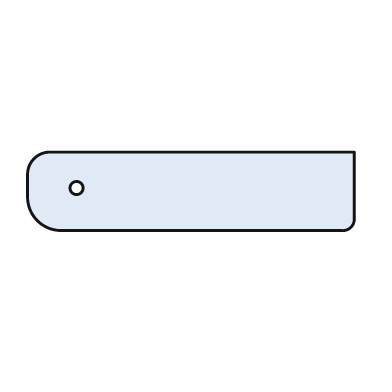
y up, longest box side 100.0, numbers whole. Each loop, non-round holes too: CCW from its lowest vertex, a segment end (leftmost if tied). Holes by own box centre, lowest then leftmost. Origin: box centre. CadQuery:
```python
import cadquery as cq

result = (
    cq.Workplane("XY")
    .moveTo(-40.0, -12.0)
    .lineTo(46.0, -12.0)
    .threePointArc((49.0, -11.0), (50.0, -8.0))
    .lineTo(50.0, 12.0)
    .lineTo(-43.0, 12.0)
    .threePointArc((-48.0, 10.0), (-50.0, 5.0))
    .lineTo(-50.0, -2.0)
    .threePointArc((-47.0, -9.0), (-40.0, -12.0))
    .close()
    .moveTo(-35.0, 1.0)
    .circle(2.0)
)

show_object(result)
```